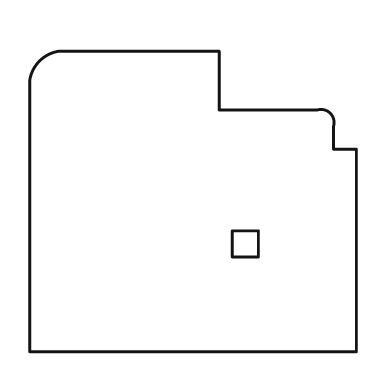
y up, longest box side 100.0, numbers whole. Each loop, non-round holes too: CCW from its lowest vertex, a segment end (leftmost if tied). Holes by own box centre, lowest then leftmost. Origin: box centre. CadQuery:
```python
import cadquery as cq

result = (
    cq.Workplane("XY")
    .moveTo(-50.0, -46.0)
    .lineTo(50.0, -46.0)
    .lineTo(50.0, 16.0)
    .lineTo(43.0, 16.0)
    .lineTo(43.0, 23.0)
    .threePointArc((42.0, 27.0), (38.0, 28.0))
    .lineTo(8.0, 28.0)
    .lineTo(8.0, 46.0)
    .lineTo(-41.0, 46.0)
    .threePointArc((-47.0, 43.0), (-50.0, 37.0))
    .close()
    .moveTo(12.0, -17.0)
    .lineTo(20.0, -17.0)
    .lineTo(20.0, -9.0)
    .lineTo(12.0, -9.0)
    .close()
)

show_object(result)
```